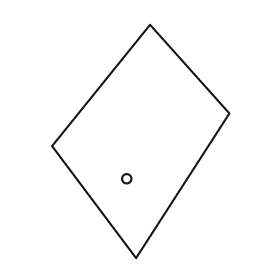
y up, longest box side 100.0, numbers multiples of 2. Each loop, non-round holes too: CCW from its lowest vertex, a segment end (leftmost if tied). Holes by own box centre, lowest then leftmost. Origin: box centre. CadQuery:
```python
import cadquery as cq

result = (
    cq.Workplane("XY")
    .moveTo(-2.0, -50.0)
    .lineTo(38.0, 12.0)
    .lineTo(4.0, 50.0)
    .lineTo(-38.0, -2.0)
    .close()
    .moveTo(-6.0, -16.0)
    .circle(2.0)
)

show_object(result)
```